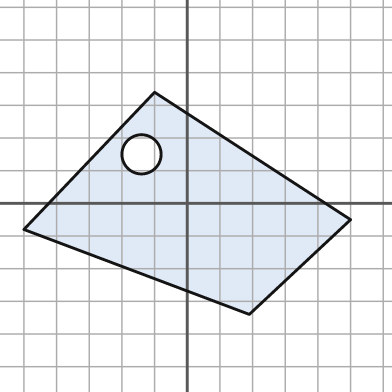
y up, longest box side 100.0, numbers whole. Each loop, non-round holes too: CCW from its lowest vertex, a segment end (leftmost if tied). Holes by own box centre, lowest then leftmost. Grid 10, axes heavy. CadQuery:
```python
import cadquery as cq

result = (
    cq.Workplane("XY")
    .moveTo(19.0, -34.0)
    .lineTo(50.0, -5.0)
    .lineTo(-10.0, 34.0)
    .lineTo(-50.0, -8.0)
    .close()
    .moveTo(-14.0, 15.0)
    .circle(6.0)
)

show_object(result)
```